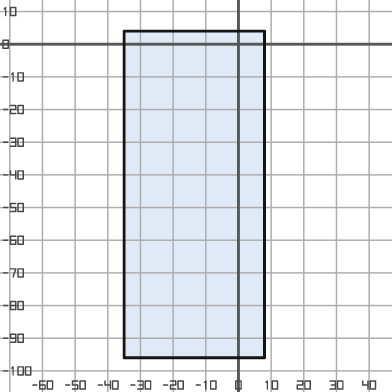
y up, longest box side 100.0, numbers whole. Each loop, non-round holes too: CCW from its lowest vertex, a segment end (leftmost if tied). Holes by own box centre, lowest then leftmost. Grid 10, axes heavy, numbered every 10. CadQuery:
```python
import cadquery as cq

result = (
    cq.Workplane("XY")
    .moveTo(-35.0, -96.0)
    .lineTo(8.0, -96.0)
    .lineTo(8.0, 4.0)
    .lineTo(-35.0, 4.0)
    .close()
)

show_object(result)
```